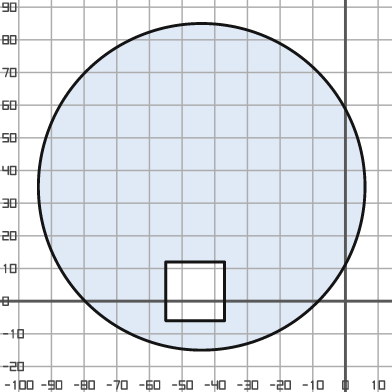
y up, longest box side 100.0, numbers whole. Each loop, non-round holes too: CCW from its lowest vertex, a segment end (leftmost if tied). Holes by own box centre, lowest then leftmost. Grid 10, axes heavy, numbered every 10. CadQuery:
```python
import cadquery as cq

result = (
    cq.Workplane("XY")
    .moveTo(-44.0, 35.0)
    .circle(50.0)
    .moveTo(-55.0, -6.0)
    .lineTo(-37.0, -6.0)
    .lineTo(-37.0, 12.0)
    .lineTo(-55.0, 12.0)
    .close()
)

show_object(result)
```